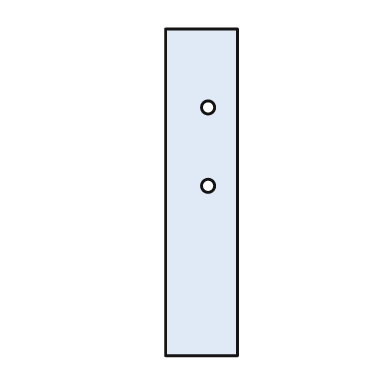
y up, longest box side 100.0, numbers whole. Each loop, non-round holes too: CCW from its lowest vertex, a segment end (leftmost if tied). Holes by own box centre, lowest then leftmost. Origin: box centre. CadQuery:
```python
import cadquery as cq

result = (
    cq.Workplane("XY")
    .moveTo(-11.0, -50.0)
    .lineTo(11.0, -50.0)
    .lineTo(11.0, 50.0)
    .lineTo(-11.0, 50.0)
    .close()
    .moveTo(2.0, 2.0)
    .circle(2.0)
    .moveTo(2.0, 26.0)
    .circle(2.0)
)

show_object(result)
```